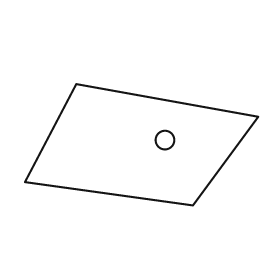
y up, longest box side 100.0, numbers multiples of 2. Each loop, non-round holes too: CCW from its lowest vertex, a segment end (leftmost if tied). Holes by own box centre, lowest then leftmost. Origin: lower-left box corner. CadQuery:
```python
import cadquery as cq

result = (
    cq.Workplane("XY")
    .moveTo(72.0, 0.0)
    .lineTo(100.0, 38.0)
    .lineTo(22.0, 52.0)
    .lineTo(0.0, 10.0)
    .close()
    .moveTo(60.0, 28.0)
    .circle(4.0)
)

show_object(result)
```